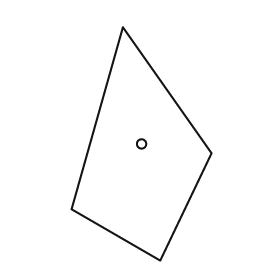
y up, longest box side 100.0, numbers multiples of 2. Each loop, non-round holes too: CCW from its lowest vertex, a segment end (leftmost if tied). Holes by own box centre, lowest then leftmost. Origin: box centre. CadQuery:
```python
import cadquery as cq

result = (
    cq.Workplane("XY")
    .moveTo(8.0, -50.0)
    .lineTo(30.0, -4.0)
    .lineTo(-8.0, 50.0)
    .lineTo(-30.0, -28.0)
    .close()
    .moveTo(0.0, 0.0)
    .circle(2.0)
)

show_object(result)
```